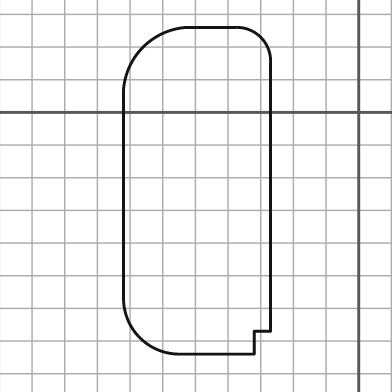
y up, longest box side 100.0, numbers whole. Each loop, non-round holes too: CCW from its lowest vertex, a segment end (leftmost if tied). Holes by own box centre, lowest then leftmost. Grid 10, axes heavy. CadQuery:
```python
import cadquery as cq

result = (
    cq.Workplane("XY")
    .moveTo(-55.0, -74.0)
    .lineTo(-32.0, -74.0)
    .lineTo(-32.0, -67.0)
    .lineTo(-27.0, -67.0)
    .lineTo(-27.0, 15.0)
    .threePointArc((-30.0, 23.0), (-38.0, 26.0))
    .lineTo(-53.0, 26.0)
    .threePointArc((-66.0, 20.0), (-72.0, 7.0))
    .lineTo(-72.0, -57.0)
    .threePointArc((-67.0, -69.0), (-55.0, -74.0))
    .close()
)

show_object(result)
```